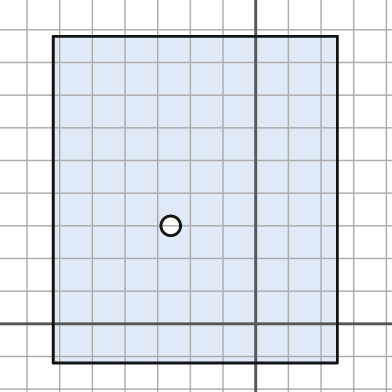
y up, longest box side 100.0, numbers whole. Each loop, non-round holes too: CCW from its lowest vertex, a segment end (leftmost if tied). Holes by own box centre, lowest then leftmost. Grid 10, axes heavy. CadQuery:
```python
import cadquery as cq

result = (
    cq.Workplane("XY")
    .moveTo(-62.0, -12.0)
    .lineTo(25.0, -12.0)
    .lineTo(25.0, 88.0)
    .lineTo(-62.0, 88.0)
    .close()
    .moveTo(-26.0, 30.0)
    .circle(3.0)
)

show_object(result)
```